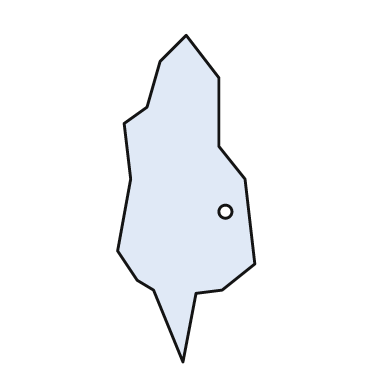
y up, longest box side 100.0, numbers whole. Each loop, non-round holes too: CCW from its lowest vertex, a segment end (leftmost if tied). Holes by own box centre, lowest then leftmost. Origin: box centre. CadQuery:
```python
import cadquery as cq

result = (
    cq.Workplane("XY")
    .moveTo(-1.0, -50.0)
    .lineTo(3.0, -29.0)
    .lineTo(11.0, -28.0)
    .lineTo(21.0, -20.0)
    .lineTo(18.0, 6.0)
    .lineTo(10.0, 16.0)
    .lineTo(10.0, 37.0)
    .lineTo(0.0, 50.0)
    .lineTo(-8.0, 42.0)
    .lineTo(-12.0, 28.0)
    .lineTo(-19.0, 23.0)
    .lineTo(-17.0, 6.0)
    .lineTo(-21.0, -16.0)
    .lineTo(-15.0, -25.0)
    .lineTo(-10.0, -28.0)
    .close()
    .moveTo(12.0, -4.0)
    .circle(2.0)
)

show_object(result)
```